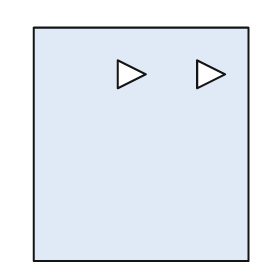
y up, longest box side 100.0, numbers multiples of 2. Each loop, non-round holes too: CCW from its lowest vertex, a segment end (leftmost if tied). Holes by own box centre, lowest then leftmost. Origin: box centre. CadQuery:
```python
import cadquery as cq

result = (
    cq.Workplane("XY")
    .moveTo(-46.0, -50.0)
    .lineTo(46.0, -50.0)
    .lineTo(46.0, 50.0)
    .lineTo(-46.0, 50.0)
    .close()
    .moveTo(-10.0, 24.0)
    .lineTo(2.0, 30.0)
    .lineTo(-10.0, 36.0)
    .close()
    .moveTo(24.0, 24.0)
    .lineTo(36.0, 30.0)
    .lineTo(24.0, 36.0)
    .close()
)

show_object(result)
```